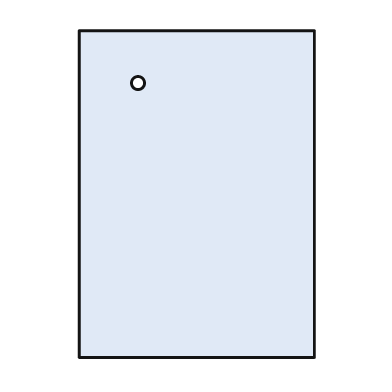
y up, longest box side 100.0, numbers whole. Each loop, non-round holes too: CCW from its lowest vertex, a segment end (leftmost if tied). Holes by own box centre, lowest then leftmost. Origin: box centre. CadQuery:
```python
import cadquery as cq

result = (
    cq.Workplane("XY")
    .moveTo(-36.0, -50.0)
    .lineTo(36.0, -50.0)
    .lineTo(36.0, 50.0)
    .lineTo(-36.0, 50.0)
    .close()
    .moveTo(-18.0, 34.0)
    .circle(2.0)
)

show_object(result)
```